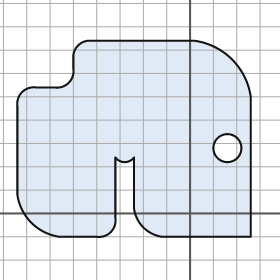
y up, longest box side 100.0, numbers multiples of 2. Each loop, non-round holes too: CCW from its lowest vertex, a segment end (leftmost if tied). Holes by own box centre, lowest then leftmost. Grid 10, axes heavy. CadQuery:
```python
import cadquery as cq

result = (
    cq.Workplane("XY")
    .moveTo(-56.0, -10.0)
    .lineTo(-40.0, -10.0)
    .threePointArc((-34.0, -8.0), (-32.0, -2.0))
    .lineTo(-32.0, 24.0)
    .threePointArc((-28.0, 22.0), (-24.0, 24.0))
    .lineTo(-24.0, 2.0)
    .threePointArc((-20.0, -6.0), (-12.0, -10.0))
    .lineTo(26.0, -10.0)
    .lineTo(26.0, 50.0)
    .threePointArc((18.0, 66.0), (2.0, 74.0))
    .lineTo(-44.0, 74.0)
    .threePointArc((-48.0, 72.0), (-50.0, 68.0))
    .lineTo(-50.0, 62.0)
    .threePointArc((-52.0, 56.0), (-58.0, 54.0))
    .lineTo(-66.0, 54.0)
    .threePointArc((-72.0, 52.0), (-74.0, 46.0))
    .lineTo(-74.0, 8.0)
    .threePointArc((-68.0, -4.0), (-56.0, -10.0))
    .close()
    .moveTo(16.0, 28.0)
    .circle(6.0)
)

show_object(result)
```